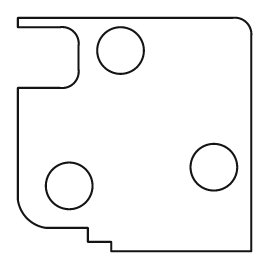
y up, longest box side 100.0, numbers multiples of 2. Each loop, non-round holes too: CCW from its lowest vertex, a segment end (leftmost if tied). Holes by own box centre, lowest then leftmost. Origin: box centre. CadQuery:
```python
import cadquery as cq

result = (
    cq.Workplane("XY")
    .moveTo(-10.0, -50.0)
    .lineTo(50.0, -50.0)
    .lineTo(50.0, 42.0)
    .threePointArc((48.0, 48.0), (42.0, 50.0))
    .lineTo(-50.0, 50.0)
    .lineTo(-50.0, 46.0)
    .lineTo(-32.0, 46.0)
    .threePointArc((-26.0, 44.0), (-24.0, 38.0))
    .lineTo(-24.0, 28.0)
    .threePointArc((-26.0, 22.0), (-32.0, 20.0))
    .lineTo(-50.0, 20.0)
    .lineTo(-50.0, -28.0)
    .threePointArc((-46.0, -36.0), (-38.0, -40.0))
    .lineTo(-20.0, -40.0)
    .lineTo(-20.0, -46.0)
    .lineTo(-10.0, -46.0)
    .close()
    .moveTo(-28.0, -22.0)
    .circle(10.0)
    .moveTo(34.0, -14.0)
    .circle(10.0)
    .moveTo(-6.0, 36.0)
    .circle(10.0)
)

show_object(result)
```